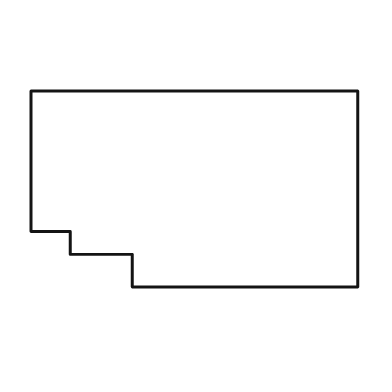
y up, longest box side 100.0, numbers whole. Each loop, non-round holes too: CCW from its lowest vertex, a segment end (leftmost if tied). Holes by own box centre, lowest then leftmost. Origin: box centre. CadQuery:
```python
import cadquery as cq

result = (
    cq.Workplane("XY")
    .moveTo(-19.0, -30.0)
    .lineTo(50.0, -30.0)
    .lineTo(50.0, 30.0)
    .lineTo(-50.0, 30.0)
    .lineTo(-50.0, -13.0)
    .lineTo(-38.0, -13.0)
    .lineTo(-38.0, -20.0)
    .lineTo(-19.0, -20.0)
    .close()
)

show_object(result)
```